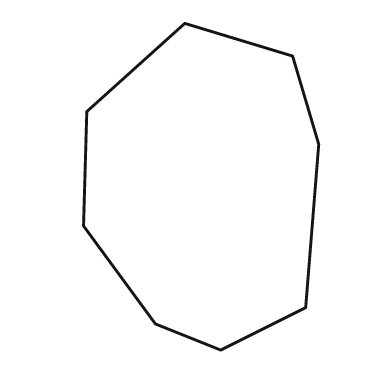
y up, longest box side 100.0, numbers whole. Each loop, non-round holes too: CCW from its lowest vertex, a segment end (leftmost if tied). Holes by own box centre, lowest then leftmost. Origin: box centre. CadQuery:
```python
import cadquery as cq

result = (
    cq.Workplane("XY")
    .moveTo(6.0, -50.0)
    .lineTo(32.0, -37.0)
    .lineTo(36.0, 13.0)
    .lineTo(28.0, 40.0)
    .lineTo(-5.0, 50.0)
    .lineTo(-35.0, 23.0)
    .lineTo(-36.0, -12.0)
    .lineTo(-14.0, -42.0)
    .close()
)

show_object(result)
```